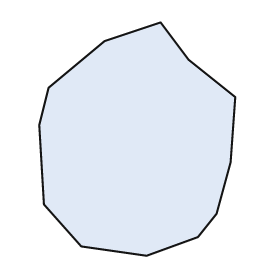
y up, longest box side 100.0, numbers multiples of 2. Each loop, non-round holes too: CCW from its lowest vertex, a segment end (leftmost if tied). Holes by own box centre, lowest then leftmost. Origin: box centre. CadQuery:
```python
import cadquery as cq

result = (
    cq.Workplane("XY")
    .moveTo(4.0, -50.0)
    .lineTo(26.0, -42.0)
    .lineTo(34.0, -32.0)
    .lineTo(40.0, -10.0)
    .lineTo(42.0, 18.0)
    .lineTo(22.0, 34.0)
    .lineTo(10.0, 50.0)
    .lineTo(-14.0, 42.0)
    .lineTo(-38.0, 22.0)
    .lineTo(-42.0, 6.0)
    .lineTo(-40.0, -28.0)
    .lineTo(-24.0, -46.0)
    .close()
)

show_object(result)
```